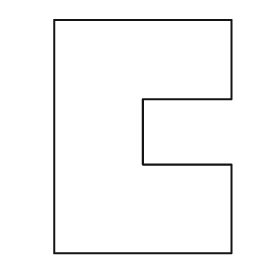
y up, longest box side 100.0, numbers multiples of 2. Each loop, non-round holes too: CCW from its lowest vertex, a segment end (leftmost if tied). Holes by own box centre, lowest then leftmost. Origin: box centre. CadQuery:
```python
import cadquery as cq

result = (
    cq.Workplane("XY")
    .moveTo(-38.0, -50.0)
    .lineTo(38.0, -50.0)
    .lineTo(38.0, -12.0)
    .lineTo(0.0, -12.0)
    .lineTo(0.0, 16.0)
    .lineTo(38.0, 16.0)
    .lineTo(38.0, 50.0)
    .lineTo(-38.0, 50.0)
    .close()
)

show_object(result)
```